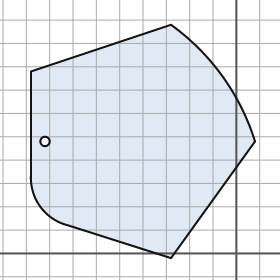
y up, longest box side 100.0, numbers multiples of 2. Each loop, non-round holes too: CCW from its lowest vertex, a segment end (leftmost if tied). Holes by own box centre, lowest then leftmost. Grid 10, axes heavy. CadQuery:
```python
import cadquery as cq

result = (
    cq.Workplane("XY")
    .moveTo(-28.0, -2.0)
    .lineTo(8.0, 48.0)
    .threePointArc((-6.0, 76.0), (-28.0, 98.0))
    .lineTo(-88.0, 78.0)
    .lineTo(-88.0, 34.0)
    .threePointArc((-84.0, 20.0), (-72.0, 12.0))
    .close()
    .moveTo(-82.0, 48.0)
    .circle(2.0)
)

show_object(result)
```